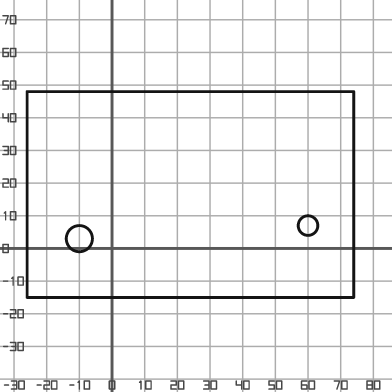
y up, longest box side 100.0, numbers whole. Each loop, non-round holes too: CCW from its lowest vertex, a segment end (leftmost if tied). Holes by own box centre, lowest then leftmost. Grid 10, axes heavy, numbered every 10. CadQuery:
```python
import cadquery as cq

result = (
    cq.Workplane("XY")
    .moveTo(-26.0, -15.0)
    .lineTo(74.0, -15.0)
    .lineTo(74.0, 48.0)
    .lineTo(-26.0, 48.0)
    .close()
    .moveTo(-10.0, 3.0)
    .circle(4.0)
    .moveTo(60.0, 7.0)
    .circle(3.0)
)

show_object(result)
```